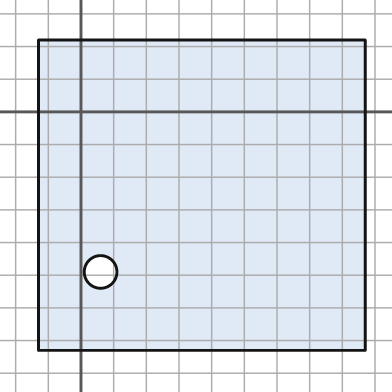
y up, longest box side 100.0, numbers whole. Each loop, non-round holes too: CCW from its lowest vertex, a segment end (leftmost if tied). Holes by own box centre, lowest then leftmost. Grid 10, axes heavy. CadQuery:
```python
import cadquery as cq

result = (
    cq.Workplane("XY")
    .moveTo(-13.0, -73.0)
    .lineTo(87.0, -73.0)
    .lineTo(87.0, 22.0)
    .lineTo(-13.0, 22.0)
    .close()
    .moveTo(6.0, -49.0)
    .circle(5.0)
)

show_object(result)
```